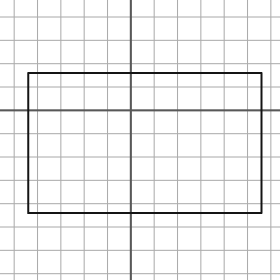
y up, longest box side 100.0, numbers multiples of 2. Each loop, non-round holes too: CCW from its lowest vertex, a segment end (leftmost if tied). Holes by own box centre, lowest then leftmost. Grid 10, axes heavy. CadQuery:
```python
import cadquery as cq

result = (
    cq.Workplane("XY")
    .moveTo(-44.0, -44.0)
    .lineTo(56.0, -44.0)
    .lineTo(56.0, 16.0)
    .lineTo(-44.0, 16.0)
    .close()
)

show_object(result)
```